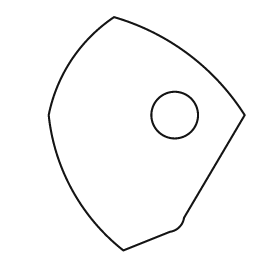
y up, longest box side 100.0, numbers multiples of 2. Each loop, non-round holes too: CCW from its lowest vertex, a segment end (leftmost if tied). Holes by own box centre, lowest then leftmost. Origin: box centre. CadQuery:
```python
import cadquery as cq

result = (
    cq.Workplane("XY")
    .moveTo(-10.0, -50.0)
    .lineTo(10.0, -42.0)
    .threePointArc((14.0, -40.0), (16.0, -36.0))
    .lineTo(42.0, 8.0)
    .threePointArc((18.0, 34.0), (-14.0, 50.0))
    .threePointArc((-32.0, 32.0), (-42.0, 8.0))
    .threePointArc((-32.0, -24.0), (-10.0, -50.0))
    .close()
    .moveTo(12.0, 8.0)
    .circle(10.0)
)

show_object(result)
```